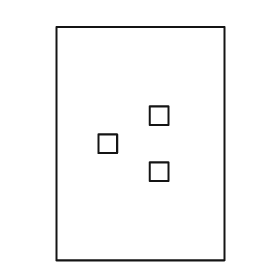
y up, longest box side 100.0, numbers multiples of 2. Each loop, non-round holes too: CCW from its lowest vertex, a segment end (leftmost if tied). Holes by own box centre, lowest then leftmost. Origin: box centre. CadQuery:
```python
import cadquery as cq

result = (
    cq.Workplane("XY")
    .moveTo(-36.0, -50.0)
    .lineTo(36.0, -50.0)
    .lineTo(36.0, 50.0)
    .lineTo(-36.0, 50.0)
    .close()
    .moveTo(4.0, -16.0)
    .lineTo(12.0, -16.0)
    .lineTo(12.0, -8.0)
    .lineTo(4.0, -8.0)
    .close()
    .moveTo(-18.0, -4.0)
    .lineTo(-10.0, -4.0)
    .lineTo(-10.0, 4.0)
    .lineTo(-18.0, 4.0)
    .close()
    .moveTo(4.0, 8.0)
    .lineTo(12.0, 8.0)
    .lineTo(12.0, 16.0)
    .lineTo(4.0, 16.0)
    .close()
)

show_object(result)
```